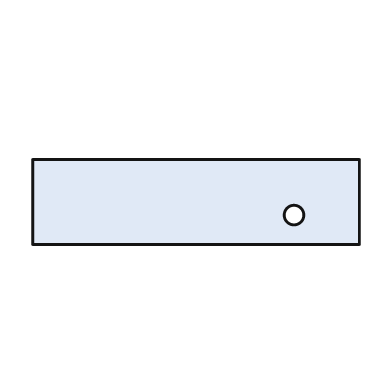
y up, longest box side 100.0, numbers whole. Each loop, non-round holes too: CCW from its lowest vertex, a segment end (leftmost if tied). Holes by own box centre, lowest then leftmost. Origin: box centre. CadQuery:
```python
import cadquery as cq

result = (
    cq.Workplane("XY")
    .moveTo(-50.0, -13.0)
    .lineTo(50.0, -13.0)
    .lineTo(50.0, 13.0)
    .lineTo(-50.0, 13.0)
    .close()
    .moveTo(30.0, -4.0)
    .circle(3.0)
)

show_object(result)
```